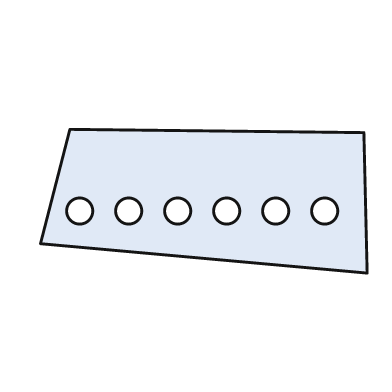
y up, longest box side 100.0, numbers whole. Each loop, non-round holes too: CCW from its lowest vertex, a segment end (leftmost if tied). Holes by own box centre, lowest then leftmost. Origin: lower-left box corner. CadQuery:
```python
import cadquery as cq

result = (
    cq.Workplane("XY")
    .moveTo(100.0, 0.0)
    .lineTo(99.0, 43.0)
    .lineTo(9.0, 44.0)
    .lineTo(0.0, 9.0)
    .close()
    .moveTo(12.0, 19.0)
    .circle(4.0)
    .moveTo(27.0, 19.0)
    .circle(4.0)
    .moveTo(42.0, 19.0)
    .circle(4.0)
    .moveTo(57.0, 19.0)
    .circle(4.0)
    .moveTo(72.0, 19.0)
    .circle(4.0)
    .moveTo(87.0, 19.0)
    .circle(4.0)
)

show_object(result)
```